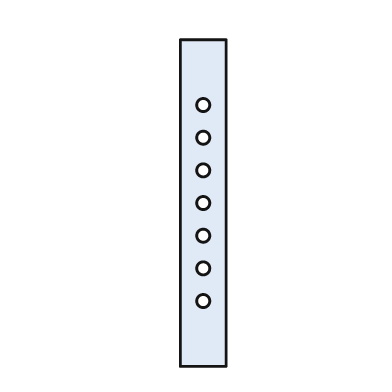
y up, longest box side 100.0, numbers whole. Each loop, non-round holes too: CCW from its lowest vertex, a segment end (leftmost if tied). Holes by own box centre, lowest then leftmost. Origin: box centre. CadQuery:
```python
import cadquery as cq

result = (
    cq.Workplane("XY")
    .moveTo(-7.0, -50.0)
    .lineTo(7.0, -50.0)
    .lineTo(7.0, 50.0)
    .lineTo(-7.0, 50.0)
    .close()
    .moveTo(0.0, -30.0)
    .circle(2.0)
    .moveTo(0.0, -20.0)
    .circle(2.0)
    .moveTo(0.0, -10.0)
    .circle(2.0)
    .moveTo(0.0, 0.0)
    .circle(2.0)
    .moveTo(0.0, 10.0)
    .circle(2.0)
    .moveTo(0.0, 20.0)
    .circle(2.0)
    .moveTo(0.0, 30.0)
    .circle(2.0)
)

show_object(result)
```